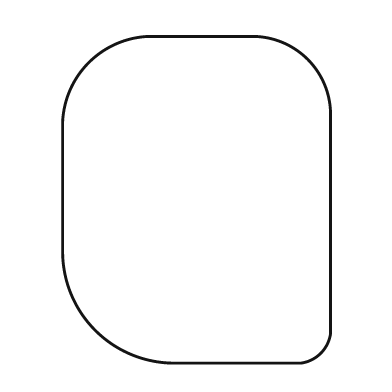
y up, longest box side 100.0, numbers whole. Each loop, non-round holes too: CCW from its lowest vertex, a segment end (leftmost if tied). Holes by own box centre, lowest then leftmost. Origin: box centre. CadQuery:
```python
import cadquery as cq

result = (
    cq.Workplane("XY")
    .moveTo(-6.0, -50.0)
    .lineTo(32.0, -50.0)
    .threePointArc((38.0, -47.0), (41.0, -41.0))
    .lineTo(41.0, 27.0)
    .threePointArc((34.0, 43.0), (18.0, 50.0))
    .lineTo(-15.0, 50.0)
    .threePointArc((-33.0, 42.0), (-41.0, 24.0))
    .lineTo(-41.0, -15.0)
    .threePointArc((-31.0, -40.0), (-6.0, -50.0))
    .close()
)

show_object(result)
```